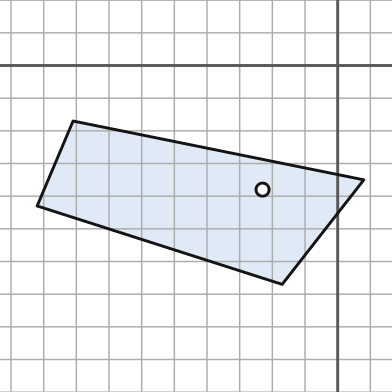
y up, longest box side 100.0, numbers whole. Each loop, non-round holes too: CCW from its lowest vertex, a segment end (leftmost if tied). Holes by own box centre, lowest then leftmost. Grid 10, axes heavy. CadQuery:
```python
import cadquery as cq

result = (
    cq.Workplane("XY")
    .moveTo(-17.0, -67.0)
    .lineTo(8.0, -35.0)
    .lineTo(-81.0, -17.0)
    .lineTo(-92.0, -43.0)
    .close()
    .moveTo(-23.0, -38.0)
    .circle(2.0)
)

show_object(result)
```